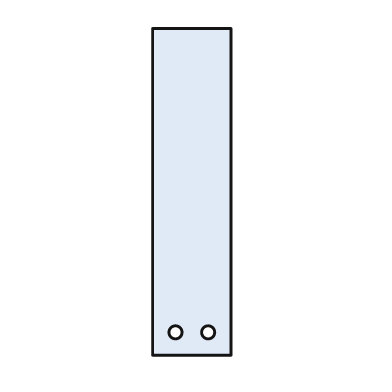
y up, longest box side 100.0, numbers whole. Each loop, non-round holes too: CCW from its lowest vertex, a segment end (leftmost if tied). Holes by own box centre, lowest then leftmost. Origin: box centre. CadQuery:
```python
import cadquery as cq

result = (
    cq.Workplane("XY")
    .moveTo(-12.0, -50.0)
    .lineTo(12.0, -50.0)
    .lineTo(12.0, 50.0)
    .lineTo(-12.0, 50.0)
    .close()
    .moveTo(-5.0, -43.0)
    .circle(2.0)
    .moveTo(5.0, -43.0)
    .circle(2.0)
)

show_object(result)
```